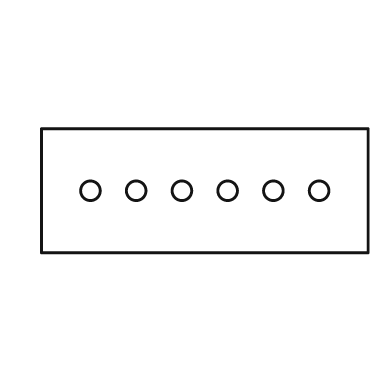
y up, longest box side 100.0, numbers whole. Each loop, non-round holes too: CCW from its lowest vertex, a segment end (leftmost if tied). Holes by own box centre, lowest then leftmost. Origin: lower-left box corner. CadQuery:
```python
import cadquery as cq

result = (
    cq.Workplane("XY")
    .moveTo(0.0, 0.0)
    .lineTo(100.0, 0.0)
    .lineTo(100.0, 38.0)
    .lineTo(0.0, 38.0)
    .close()
    .moveTo(15.0, 19.0)
    .circle(3.0)
    .moveTo(29.0, 19.0)
    .circle(3.0)
    .moveTo(43.0, 19.0)
    .circle(3.0)
    .moveTo(57.0, 19.0)
    .circle(3.0)
    .moveTo(71.0, 19.0)
    .circle(3.0)
    .moveTo(85.0, 19.0)
    .circle(3.0)
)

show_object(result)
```